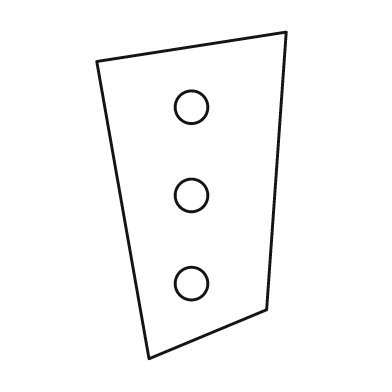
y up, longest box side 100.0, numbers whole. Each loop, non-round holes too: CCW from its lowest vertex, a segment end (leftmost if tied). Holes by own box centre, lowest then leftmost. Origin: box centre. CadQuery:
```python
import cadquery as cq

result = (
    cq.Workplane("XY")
    .moveTo(-13.0, -50.0)
    .lineTo(23.0, -35.0)
    .lineTo(29.0, 50.0)
    .lineTo(-29.0, 41.0)
    .close()
    .moveTo(0.0, -27.0)
    .circle(5.0)
    .moveTo(0.0, 0.0)
    .circle(5.0)
    .moveTo(0.0, 27.0)
    .circle(5.0)
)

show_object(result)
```